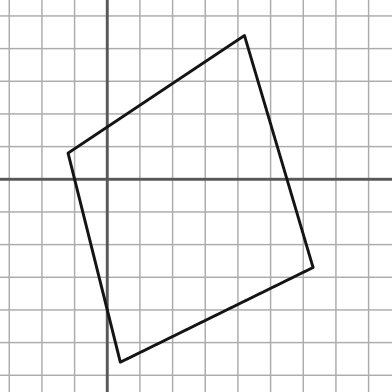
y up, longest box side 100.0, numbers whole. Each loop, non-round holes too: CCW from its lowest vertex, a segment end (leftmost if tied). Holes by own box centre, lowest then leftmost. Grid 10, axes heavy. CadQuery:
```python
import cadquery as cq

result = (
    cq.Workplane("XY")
    .moveTo(4.0, -56.0)
    .lineTo(63.0, -27.0)
    .lineTo(42.0, 44.0)
    .lineTo(-12.0, 8.0)
    .close()
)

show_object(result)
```